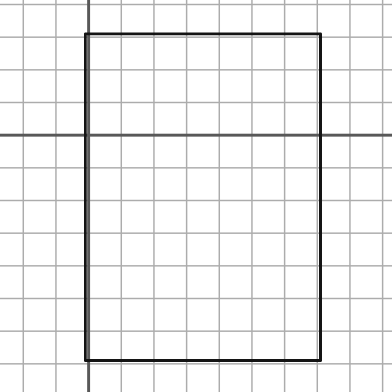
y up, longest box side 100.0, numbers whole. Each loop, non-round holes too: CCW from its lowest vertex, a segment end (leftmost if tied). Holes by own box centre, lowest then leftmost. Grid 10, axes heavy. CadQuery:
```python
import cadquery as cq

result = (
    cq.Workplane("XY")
    .moveTo(-1.0, -69.0)
    .lineTo(71.0, -69.0)
    .lineTo(71.0, 31.0)
    .lineTo(-1.0, 31.0)
    .close()
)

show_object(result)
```